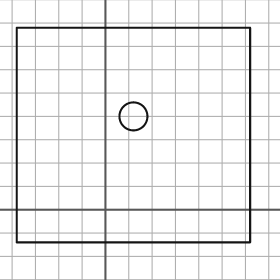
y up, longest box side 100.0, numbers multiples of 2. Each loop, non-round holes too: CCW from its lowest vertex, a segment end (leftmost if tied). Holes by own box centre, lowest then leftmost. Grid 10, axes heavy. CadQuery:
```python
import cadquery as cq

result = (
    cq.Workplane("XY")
    .moveTo(-38.0, -14.0)
    .lineTo(62.0, -14.0)
    .lineTo(62.0, 78.0)
    .lineTo(-38.0, 78.0)
    .close()
    .moveTo(12.0, 40.0)
    .circle(6.0)
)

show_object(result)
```